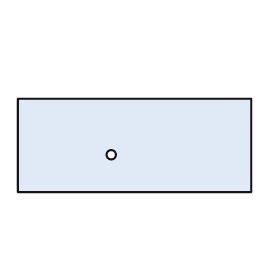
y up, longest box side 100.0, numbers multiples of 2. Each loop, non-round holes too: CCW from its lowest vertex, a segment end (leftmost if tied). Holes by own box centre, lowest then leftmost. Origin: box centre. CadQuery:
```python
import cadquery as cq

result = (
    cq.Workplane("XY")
    .moveTo(-50.0, -20.0)
    .lineTo(50.0, -20.0)
    .lineTo(50.0, 20.0)
    .lineTo(-50.0, 20.0)
    .close()
    .moveTo(-10.0, -4.0)
    .circle(2.0)
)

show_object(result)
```